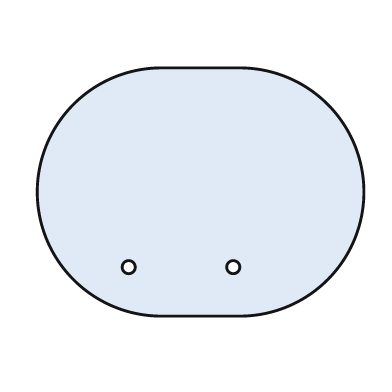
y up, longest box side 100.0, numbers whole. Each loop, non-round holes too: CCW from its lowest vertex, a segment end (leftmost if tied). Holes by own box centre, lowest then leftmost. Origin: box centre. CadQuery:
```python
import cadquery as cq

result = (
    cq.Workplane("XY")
    .moveTo(-12.0, -38.0)
    .lineTo(12.0, -38.0)
    .threePointArc((50.0, 0.0), (12.0, 38.0))
    .lineTo(-12.0, 38.0)
    .threePointArc((-50.0, 0.0), (-12.0, -38.0))
    .close()
    .moveTo(-22.0, -23.0)
    .circle(2.0)
    .moveTo(10.0, -23.0)
    .circle(2.0)
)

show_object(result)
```